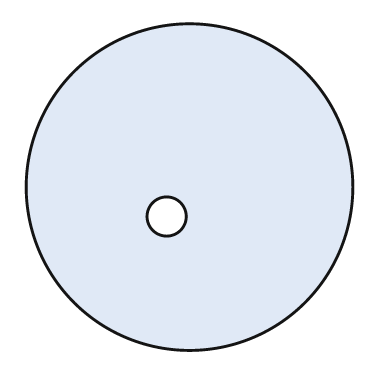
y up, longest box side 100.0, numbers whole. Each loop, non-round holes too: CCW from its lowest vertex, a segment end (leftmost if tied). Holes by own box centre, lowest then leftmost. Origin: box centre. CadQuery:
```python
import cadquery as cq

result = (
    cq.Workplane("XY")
    .moveTo(0.0, 0.0)
    .circle(50.0)
    .moveTo(-7.0, -9.0)
    .circle(6.0)
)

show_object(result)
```